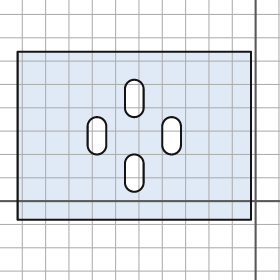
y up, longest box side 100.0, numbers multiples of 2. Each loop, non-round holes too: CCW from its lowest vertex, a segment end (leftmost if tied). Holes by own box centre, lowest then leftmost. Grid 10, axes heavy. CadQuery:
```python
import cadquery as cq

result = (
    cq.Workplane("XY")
    .moveTo(-102.0, -8.0)
    .lineTo(-2.0, -8.0)
    .lineTo(-2.0, 64.0)
    .lineTo(-102.0, 64.0)
    .close()
    .moveTo(-56.0, 8.0)
    .threePointArc((-52.0, 4.0), (-48.0, 8.0))
    .lineTo(-48.0, 16.0)
    .threePointArc((-52.0, 20.0), (-56.0, 16.0))
    .close()
    .moveTo(-72.0, 24.0)
    .threePointArc((-68.0, 20.0), (-64.0, 24.0))
    .lineTo(-64.0, 32.0)
    .threePointArc((-68.0, 36.0), (-72.0, 32.0))
    .close()
    .moveTo(-40.0, 24.0)
    .threePointArc((-36.0, 20.0), (-32.0, 24.0))
    .lineTo(-32.0, 32.0)
    .threePointArc((-36.0, 36.0), (-40.0, 32.0))
    .close()
    .moveTo(-56.0, 40.0)
    .threePointArc((-52.0, 36.0), (-48.0, 40.0))
    .lineTo(-48.0, 48.0)
    .threePointArc((-52.0, 52.0), (-56.0, 48.0))
    .close()
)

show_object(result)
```